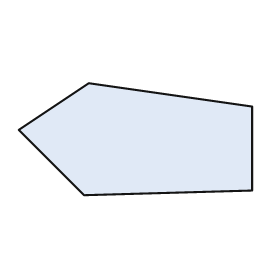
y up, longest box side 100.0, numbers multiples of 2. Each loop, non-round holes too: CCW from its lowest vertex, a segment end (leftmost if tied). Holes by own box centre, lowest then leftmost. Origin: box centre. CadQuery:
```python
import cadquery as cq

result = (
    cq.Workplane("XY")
    .moveTo(-22.0, -24.0)
    .lineTo(50.0, -22.0)
    .lineTo(50.0, 14.0)
    .lineTo(-20.0, 24.0)
    .lineTo(-50.0, 4.0)
    .close()
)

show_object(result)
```